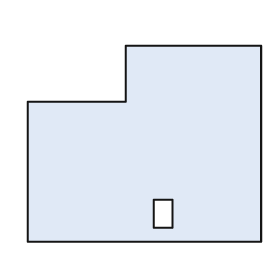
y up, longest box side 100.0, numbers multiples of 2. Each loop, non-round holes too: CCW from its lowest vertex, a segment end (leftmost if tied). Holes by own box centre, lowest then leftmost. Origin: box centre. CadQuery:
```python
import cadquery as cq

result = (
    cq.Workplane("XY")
    .moveTo(-50.0, -42.0)
    .lineTo(50.0, -42.0)
    .lineTo(50.0, 42.0)
    .lineTo(-8.0, 42.0)
    .lineTo(-8.0, 18.0)
    .lineTo(-50.0, 18.0)
    .close()
    .moveTo(4.0, -36.0)
    .lineTo(12.0, -36.0)
    .lineTo(12.0, -24.0)
    .lineTo(4.0, -24.0)
    .close()
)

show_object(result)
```